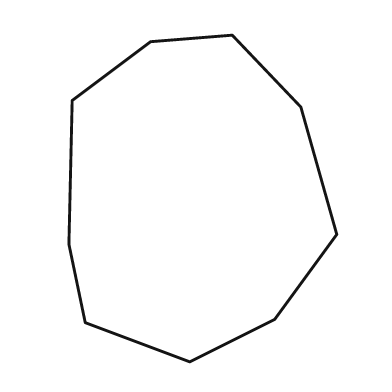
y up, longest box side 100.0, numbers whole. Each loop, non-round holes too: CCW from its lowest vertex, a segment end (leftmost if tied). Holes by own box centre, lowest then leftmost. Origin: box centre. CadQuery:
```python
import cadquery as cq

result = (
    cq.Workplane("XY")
    .moveTo(-4.0, -50.0)
    .lineTo(22.0, -37.0)
    .lineTo(41.0, -11.0)
    .lineTo(30.0, 28.0)
    .lineTo(9.0, 50.0)
    .lineTo(-16.0, 48.0)
    .lineTo(-40.0, 30.0)
    .lineTo(-41.0, -14.0)
    .lineTo(-36.0, -38.0)
    .close()
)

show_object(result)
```